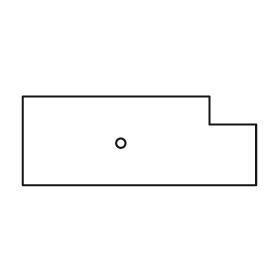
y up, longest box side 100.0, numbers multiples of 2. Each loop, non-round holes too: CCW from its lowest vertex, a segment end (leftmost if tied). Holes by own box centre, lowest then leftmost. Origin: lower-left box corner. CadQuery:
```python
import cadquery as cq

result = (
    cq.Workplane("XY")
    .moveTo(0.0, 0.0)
    .lineTo(100.0, 0.0)
    .lineTo(100.0, 26.0)
    .lineTo(80.0, 26.0)
    .lineTo(80.0, 38.0)
    .lineTo(0.0, 38.0)
    .close()
    .moveTo(42.0, 18.0)
    .circle(2.0)
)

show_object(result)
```